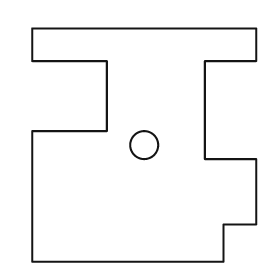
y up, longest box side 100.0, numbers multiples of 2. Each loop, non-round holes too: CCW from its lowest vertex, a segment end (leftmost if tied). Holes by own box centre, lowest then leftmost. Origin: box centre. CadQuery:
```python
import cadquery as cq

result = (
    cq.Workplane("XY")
    .moveTo(-48.0, -50.0)
    .lineTo(34.0, -50.0)
    .lineTo(34.0, -34.0)
    .lineTo(48.0, -34.0)
    .lineTo(48.0, -6.0)
    .lineTo(26.0, -6.0)
    .lineTo(26.0, 36.0)
    .lineTo(48.0, 36.0)
    .lineTo(48.0, 50.0)
    .lineTo(-48.0, 50.0)
    .lineTo(-48.0, 36.0)
    .lineTo(-16.0, 36.0)
    .lineTo(-16.0, 6.0)
    .lineTo(-48.0, 6.0)
    .close()
    .moveTo(0.0, 0.0)
    .circle(6.0)
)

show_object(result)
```